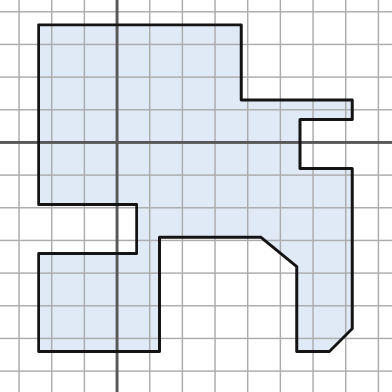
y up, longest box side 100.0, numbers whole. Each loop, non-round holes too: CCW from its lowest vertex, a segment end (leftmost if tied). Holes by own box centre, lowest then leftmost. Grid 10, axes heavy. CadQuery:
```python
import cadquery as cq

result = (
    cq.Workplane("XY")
    .moveTo(-24.0, -64.0)
    .lineTo(13.0, -64.0)
    .lineTo(13.0, -29.0)
    .lineTo(44.0, -29.0)
    .lineTo(55.0, -38.0)
    .lineTo(55.0, -64.0)
    .lineTo(65.0, -64.0)
    .lineTo(72.0, -57.0)
    .lineTo(72.0, -8.0)
    .lineTo(56.0, -8.0)
    .lineTo(56.0, 7.0)
    .lineTo(72.0, 7.0)
    .lineTo(72.0, 13.0)
    .lineTo(38.0, 13.0)
    .lineTo(38.0, 36.0)
    .lineTo(-24.0, 36.0)
    .lineTo(-24.0, -19.0)
    .lineTo(6.0, -19.0)
    .lineTo(6.0, -34.0)
    .lineTo(-24.0, -34.0)
    .close()
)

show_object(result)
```